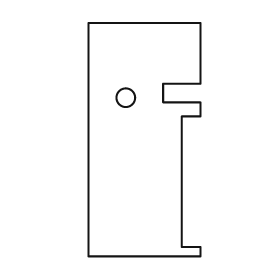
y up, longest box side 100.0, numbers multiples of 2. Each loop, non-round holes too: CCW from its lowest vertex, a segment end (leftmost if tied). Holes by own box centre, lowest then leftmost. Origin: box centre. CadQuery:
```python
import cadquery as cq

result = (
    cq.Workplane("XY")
    .moveTo(-24.0, -50.0)
    .lineTo(24.0, -50.0)
    .lineTo(24.0, -46.0)
    .lineTo(16.0, -46.0)
    .lineTo(16.0, 10.0)
    .lineTo(24.0, 10.0)
    .lineTo(24.0, 16.0)
    .lineTo(8.0, 16.0)
    .lineTo(8.0, 24.0)
    .lineTo(24.0, 24.0)
    .lineTo(24.0, 50.0)
    .lineTo(-24.0, 50.0)
    .close()
    .moveTo(-8.0, 18.0)
    .circle(4.0)
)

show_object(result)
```